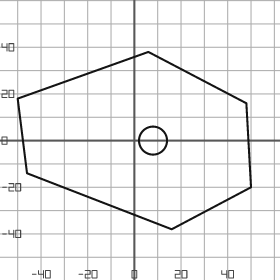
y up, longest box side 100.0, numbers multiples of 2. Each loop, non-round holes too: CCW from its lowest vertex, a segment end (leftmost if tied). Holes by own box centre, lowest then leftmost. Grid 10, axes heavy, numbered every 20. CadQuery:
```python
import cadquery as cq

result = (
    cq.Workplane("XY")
    .moveTo(16.0, -38.0)
    .lineTo(50.0, -20.0)
    .lineTo(48.0, 16.0)
    .lineTo(6.0, 38.0)
    .lineTo(-50.0, 18.0)
    .lineTo(-46.0, -14.0)
    .close()
    .moveTo(8.0, 0.0)
    .circle(6.0)
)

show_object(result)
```